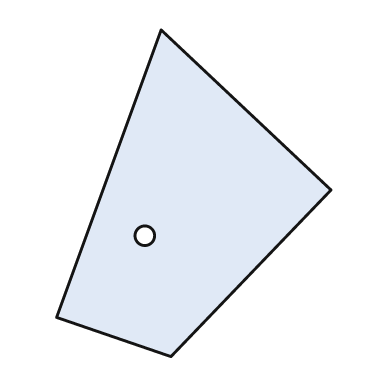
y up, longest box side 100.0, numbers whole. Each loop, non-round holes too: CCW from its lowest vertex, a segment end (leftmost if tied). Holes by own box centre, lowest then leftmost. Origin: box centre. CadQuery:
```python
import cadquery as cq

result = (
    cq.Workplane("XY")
    .moveTo(-7.0, -50.0)
    .lineTo(42.0, 1.0)
    .lineTo(-10.0, 50.0)
    .lineTo(-42.0, -38.0)
    .close()
    .moveTo(-15.0, -13.0)
    .circle(3.0)
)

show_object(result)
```